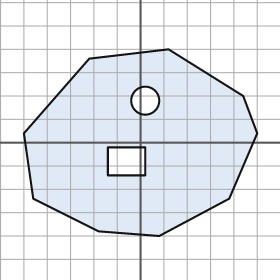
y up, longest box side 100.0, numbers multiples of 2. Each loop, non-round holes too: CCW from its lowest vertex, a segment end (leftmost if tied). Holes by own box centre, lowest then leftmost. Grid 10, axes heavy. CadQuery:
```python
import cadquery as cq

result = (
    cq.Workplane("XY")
    .moveTo(8.0, -40.0)
    .lineTo(38.0, -24.0)
    .lineTo(50.0, 4.0)
    .lineTo(44.0, 20.0)
    .lineTo(12.0, 40.0)
    .lineTo(-22.0, 36.0)
    .lineTo(-50.0, 4.0)
    .lineTo(-46.0, -24.0)
    .lineTo(-18.0, -38.0)
    .close()
    .moveTo(-14.0, -14.0)
    .lineTo(2.0, -14.0)
    .lineTo(2.0, -2.0)
    .lineTo(-14.0, -2.0)
    .close()
    .moveTo(2.0, 18.0)
    .circle(6.0)
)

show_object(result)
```